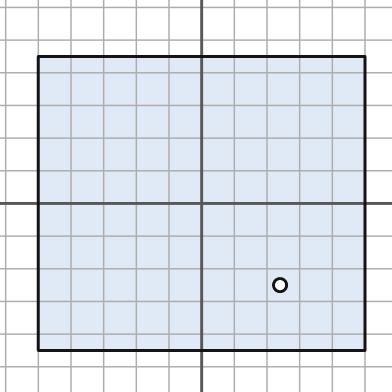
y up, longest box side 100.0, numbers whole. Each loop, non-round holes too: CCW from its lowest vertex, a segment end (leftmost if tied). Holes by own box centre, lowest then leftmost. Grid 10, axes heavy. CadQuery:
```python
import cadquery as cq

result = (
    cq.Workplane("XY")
    .moveTo(-50.0, -45.0)
    .lineTo(50.0, -45.0)
    .lineTo(50.0, 45.0)
    .lineTo(-50.0, 45.0)
    .close()
    .moveTo(24.0, -25.0)
    .circle(2.0)
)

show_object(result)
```